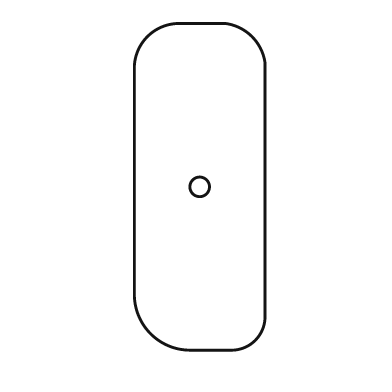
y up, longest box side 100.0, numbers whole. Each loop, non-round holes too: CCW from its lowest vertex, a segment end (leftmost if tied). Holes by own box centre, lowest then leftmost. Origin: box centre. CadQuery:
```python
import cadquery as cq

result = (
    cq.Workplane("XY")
    .moveTo(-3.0, -50.0)
    .lineTo(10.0, -50.0)
    .threePointArc((17.0, -47.0), (20.0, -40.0))
    .lineTo(20.0, 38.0)
    .threePointArc((16.0, 46.0), (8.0, 50.0))
    .lineTo(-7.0, 50.0)
    .threePointArc((-16.0, 46.0), (-20.0, 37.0))
    .lineTo(-20.0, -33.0)
    .threePointArc((-15.0, -45.0), (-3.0, -50.0))
    .close()
    .moveTo(0.0, 0.0)
    .circle(3.0)
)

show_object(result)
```